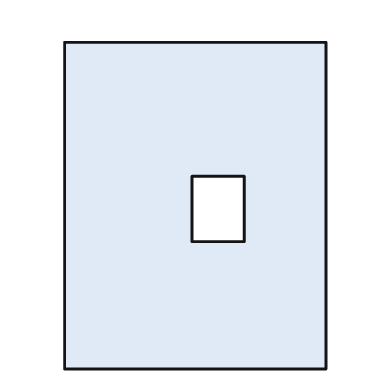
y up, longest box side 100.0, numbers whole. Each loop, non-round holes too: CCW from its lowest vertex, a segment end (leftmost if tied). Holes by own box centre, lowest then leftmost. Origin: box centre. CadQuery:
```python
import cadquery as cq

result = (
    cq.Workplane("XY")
    .moveTo(-40.0, -50.0)
    .lineTo(40.0, -50.0)
    .lineTo(40.0, 50.0)
    .lineTo(-40.0, 50.0)
    .close()
    .moveTo(-1.0, -11.0)
    .lineTo(15.0, -11.0)
    .lineTo(15.0, 9.0)
    .lineTo(-1.0, 9.0)
    .close()
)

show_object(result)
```